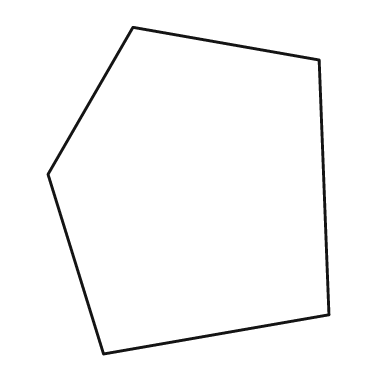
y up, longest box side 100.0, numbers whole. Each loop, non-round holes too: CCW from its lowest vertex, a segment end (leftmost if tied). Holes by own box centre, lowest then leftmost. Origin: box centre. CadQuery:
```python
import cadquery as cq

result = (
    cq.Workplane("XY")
    .moveTo(-26.0, -50.0)
    .lineTo(43.0, -38.0)
    .lineTo(40.0, 40.0)
    .lineTo(-17.0, 50.0)
    .lineTo(-43.0, 5.0)
    .close()
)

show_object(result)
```